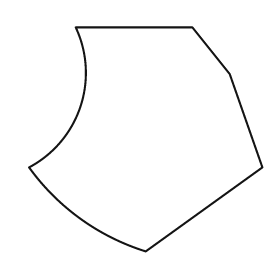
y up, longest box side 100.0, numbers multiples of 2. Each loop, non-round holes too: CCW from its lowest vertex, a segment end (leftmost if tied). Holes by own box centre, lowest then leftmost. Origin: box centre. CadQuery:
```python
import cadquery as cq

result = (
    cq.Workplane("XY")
    .moveTo(0.0, -48.0)
    .lineTo(50.0, -12.0)
    .lineTo(36.0, 28.0)
    .lineTo(20.0, 48.0)
    .lineTo(-30.0, 48.0)
    .threePointArc((-28.0, 14.0), (-50.0, -12.0))
    .threePointArc((-28.0, -34.0), (0.0, -48.0))
    .close()
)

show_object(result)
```